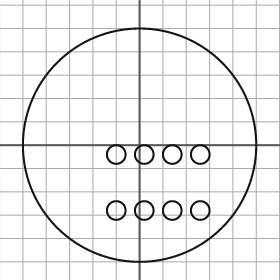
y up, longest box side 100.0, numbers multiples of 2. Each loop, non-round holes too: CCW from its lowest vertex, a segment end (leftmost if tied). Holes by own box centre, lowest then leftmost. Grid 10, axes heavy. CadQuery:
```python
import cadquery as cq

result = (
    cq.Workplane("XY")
    .moveTo(0.0, 0.0)
    .circle(50.0)
    .moveTo(-10.0, -28.0)
    .circle(4.0)
    .moveTo(2.0, -28.0)
    .circle(4.0)
    .moveTo(14.0, -28.0)
    .circle(4.0)
    .moveTo(26.0, -28.0)
    .circle(4.0)
    .moveTo(-10.0, -4.0)
    .circle(4.0)
    .moveTo(2.0, -4.0)
    .circle(4.0)
    .moveTo(14.0, -4.0)
    .circle(4.0)
    .moveTo(26.0, -4.0)
    .circle(4.0)
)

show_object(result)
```